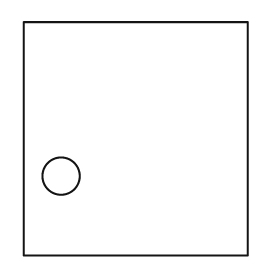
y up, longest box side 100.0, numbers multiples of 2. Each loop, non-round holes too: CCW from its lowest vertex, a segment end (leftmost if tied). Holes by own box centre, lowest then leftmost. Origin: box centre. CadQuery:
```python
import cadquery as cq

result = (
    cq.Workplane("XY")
    .moveTo(-48.0, -50.0)
    .lineTo(48.0, -50.0)
    .lineTo(48.0, 50.0)
    .lineTo(-48.0, 50.0)
    .close()
    .moveTo(-32.0, -16.0)
    .circle(8.0)
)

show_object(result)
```